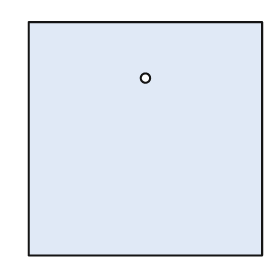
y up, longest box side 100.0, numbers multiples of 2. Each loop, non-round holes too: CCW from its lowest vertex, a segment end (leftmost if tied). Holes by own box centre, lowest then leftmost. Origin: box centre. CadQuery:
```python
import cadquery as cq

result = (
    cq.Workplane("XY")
    .moveTo(-50.0, -50.0)
    .lineTo(50.0, -50.0)
    .lineTo(50.0, 50.0)
    .lineTo(-50.0, 50.0)
    .close()
    .moveTo(0.0, 26.0)
    .circle(2.0)
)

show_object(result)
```